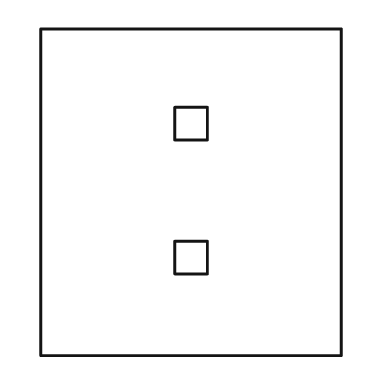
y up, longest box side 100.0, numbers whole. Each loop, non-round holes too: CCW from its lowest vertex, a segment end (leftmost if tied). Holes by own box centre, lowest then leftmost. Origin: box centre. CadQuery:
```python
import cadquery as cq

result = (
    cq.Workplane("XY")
    .moveTo(-46.0, -50.0)
    .lineTo(46.0, -50.0)
    .lineTo(46.0, 50.0)
    .lineTo(-46.0, 50.0)
    .close()
    .moveTo(-5.0, -25.0)
    .lineTo(5.0, -25.0)
    .lineTo(5.0, -15.0)
    .lineTo(-5.0, -15.0)
    .close()
    .moveTo(-5.0, 16.0)
    .lineTo(5.0, 16.0)
    .lineTo(5.0, 26.0)
    .lineTo(-5.0, 26.0)
    .close()
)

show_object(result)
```